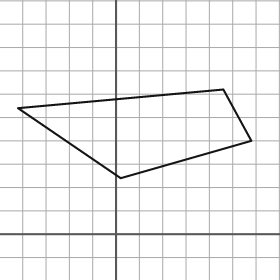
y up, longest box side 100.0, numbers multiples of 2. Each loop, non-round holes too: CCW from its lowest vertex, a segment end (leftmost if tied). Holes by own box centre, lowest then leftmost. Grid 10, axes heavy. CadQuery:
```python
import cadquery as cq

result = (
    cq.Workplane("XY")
    .moveTo(2.0, 24.0)
    .lineTo(58.0, 40.0)
    .lineTo(46.0, 62.0)
    .lineTo(-42.0, 54.0)
    .close()
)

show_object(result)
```